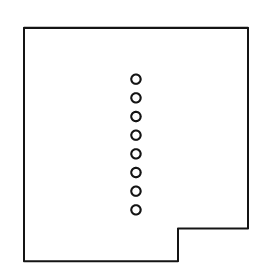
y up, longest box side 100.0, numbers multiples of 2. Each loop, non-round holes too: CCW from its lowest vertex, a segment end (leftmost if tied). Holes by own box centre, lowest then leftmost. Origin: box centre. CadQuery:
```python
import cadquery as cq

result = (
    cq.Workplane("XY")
    .moveTo(-48.0, -50.0)
    .lineTo(18.0, -50.0)
    .lineTo(18.0, -36.0)
    .lineTo(48.0, -36.0)
    .lineTo(48.0, 50.0)
    .lineTo(-48.0, 50.0)
    .close()
    .moveTo(0.0, -28.0)
    .circle(2.0)
    .moveTo(0.0, -20.0)
    .circle(2.0)
    .moveTo(0.0, -12.0)
    .circle(2.0)
    .moveTo(0.0, -4.0)
    .circle(2.0)
    .moveTo(0.0, 4.0)
    .circle(2.0)
    .moveTo(0.0, 12.0)
    .circle(2.0)
    .moveTo(0.0, 20.0)
    .circle(2.0)
    .moveTo(0.0, 28.0)
    .circle(2.0)
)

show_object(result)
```